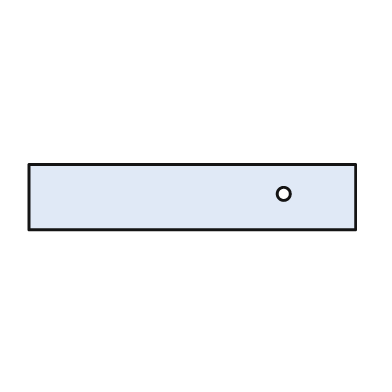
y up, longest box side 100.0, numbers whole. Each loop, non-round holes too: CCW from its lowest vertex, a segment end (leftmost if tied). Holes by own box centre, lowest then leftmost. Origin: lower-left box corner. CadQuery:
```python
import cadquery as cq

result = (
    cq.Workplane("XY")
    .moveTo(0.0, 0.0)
    .lineTo(100.0, 0.0)
    .lineTo(100.0, 20.0)
    .lineTo(0.0, 20.0)
    .close()
    .moveTo(78.0, 11.0)
    .circle(2.0)
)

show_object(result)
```